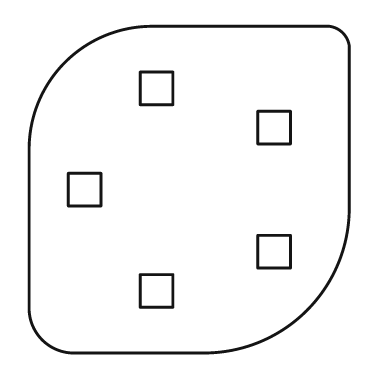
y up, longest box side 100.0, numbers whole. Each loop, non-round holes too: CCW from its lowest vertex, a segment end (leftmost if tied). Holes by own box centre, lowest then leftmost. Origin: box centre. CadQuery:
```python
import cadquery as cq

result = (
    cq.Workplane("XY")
    .moveTo(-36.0, -50.0)
    .lineTo(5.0, -50.0)
    .threePointArc((36.0, -37.0), (49.0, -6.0))
    .lineTo(49.0, 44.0)
    .threePointArc((47.0, 48.0), (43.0, 50.0))
    .lineTo(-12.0, 50.0)
    .threePointArc((-38.0, 39.0), (-49.0, 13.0))
    .lineTo(-49.0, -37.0)
    .threePointArc((-45.0, -46.0), (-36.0, -50.0))
    .close()
    .moveTo(-15.0, -36.0)
    .lineTo(-5.0, -36.0)
    .lineTo(-5.0, -26.0)
    .lineTo(-15.0, -26.0)
    .close()
    .moveTo(21.0, -24.0)
    .lineTo(31.0, -24.0)
    .lineTo(31.0, -14.0)
    .lineTo(21.0, -14.0)
    .close()
    .moveTo(-37.0, -5.0)
    .lineTo(-27.0, -5.0)
    .lineTo(-27.0, 5.0)
    .lineTo(-37.0, 5.0)
    .close()
    .moveTo(21.0, 14.0)
    .lineTo(31.0, 14.0)
    .lineTo(31.0, 24.0)
    .lineTo(21.0, 24.0)
    .close()
    .moveTo(-15.0, 26.0)
    .lineTo(-5.0, 26.0)
    .lineTo(-5.0, 36.0)
    .lineTo(-15.0, 36.0)
    .close()
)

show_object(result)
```